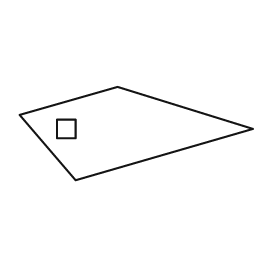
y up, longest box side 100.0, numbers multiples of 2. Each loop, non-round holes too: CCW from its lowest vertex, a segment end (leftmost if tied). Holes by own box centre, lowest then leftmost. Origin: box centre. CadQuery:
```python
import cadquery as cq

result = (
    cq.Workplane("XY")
    .moveTo(-26.0, -20.0)
    .lineTo(50.0, 2.0)
    .lineTo(-8.0, 20.0)
    .lineTo(-50.0, 8.0)
    .close()
    .moveTo(-34.0, -2.0)
    .lineTo(-26.0, -2.0)
    .lineTo(-26.0, 6.0)
    .lineTo(-34.0, 6.0)
    .close()
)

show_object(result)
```